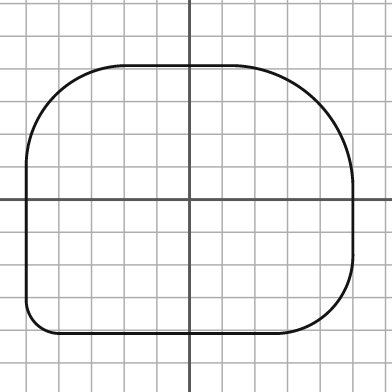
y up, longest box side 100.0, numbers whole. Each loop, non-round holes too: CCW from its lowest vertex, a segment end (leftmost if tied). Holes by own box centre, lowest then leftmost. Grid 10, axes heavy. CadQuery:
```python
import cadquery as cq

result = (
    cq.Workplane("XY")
    .moveTo(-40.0, -41.0)
    .lineTo(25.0, -41.0)
    .threePointArc((43.0, -34.0), (50.0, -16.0))
    .lineTo(50.0, 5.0)
    .threePointArc((39.0, 30.0), (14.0, 41.0))
    .lineTo(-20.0, 41.0)
    .threePointArc((-41.0, 32.0), (-50.0, 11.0))
    .lineTo(-50.0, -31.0)
    .threePointArc((-47.0, -38.0), (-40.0, -41.0))
    .close()
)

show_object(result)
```